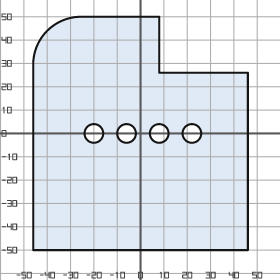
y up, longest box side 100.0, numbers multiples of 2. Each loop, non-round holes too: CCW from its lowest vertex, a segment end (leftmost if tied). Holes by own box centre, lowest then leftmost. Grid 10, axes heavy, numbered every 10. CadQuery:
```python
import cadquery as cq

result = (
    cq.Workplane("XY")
    .moveTo(-46.0, -50.0)
    .lineTo(46.0, -50.0)
    .lineTo(46.0, 26.0)
    .lineTo(8.0, 26.0)
    .lineTo(8.0, 50.0)
    .lineTo(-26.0, 50.0)
    .threePointArc((-40.0, 44.0), (-46.0, 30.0))
    .close()
    .moveTo(-20.0, 0.0)
    .circle(4.0)
    .moveTo(-6.0, 0.0)
    .circle(4.0)
    .moveTo(8.0, 0.0)
    .circle(4.0)
    .moveTo(22.0, 0.0)
    .circle(4.0)
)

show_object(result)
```